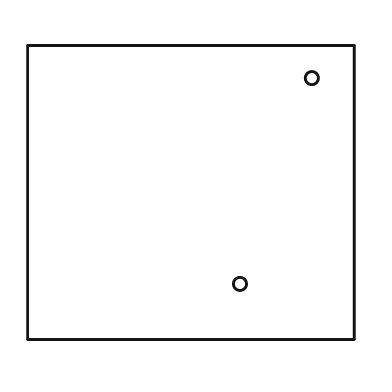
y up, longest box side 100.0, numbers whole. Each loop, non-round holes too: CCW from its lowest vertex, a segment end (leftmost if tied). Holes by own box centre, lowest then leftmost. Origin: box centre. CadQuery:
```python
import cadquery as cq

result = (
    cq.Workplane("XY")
    .moveTo(-50.0, -45.0)
    .lineTo(50.0, -45.0)
    .lineTo(50.0, 45.0)
    .lineTo(-50.0, 45.0)
    .close()
    .moveTo(15.0, -28.0)
    .circle(2.0)
    .moveTo(37.0, 35.0)
    .circle(2.0)
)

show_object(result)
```